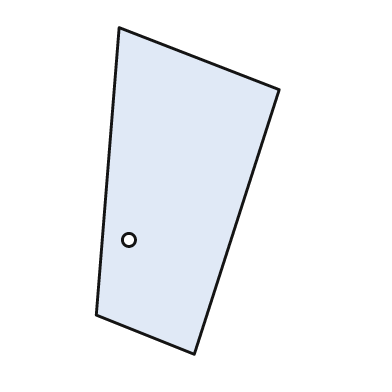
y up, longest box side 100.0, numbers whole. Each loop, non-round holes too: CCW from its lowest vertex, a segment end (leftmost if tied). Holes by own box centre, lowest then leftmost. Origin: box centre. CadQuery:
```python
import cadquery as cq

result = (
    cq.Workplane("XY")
    .moveTo(2.0, -50.0)
    .lineTo(28.0, 31.0)
    .lineTo(-21.0, 50.0)
    .lineTo(-28.0, -38.0)
    .close()
    .moveTo(-18.0, -15.0)
    .circle(2.0)
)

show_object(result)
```